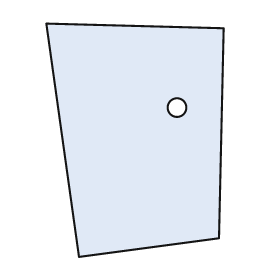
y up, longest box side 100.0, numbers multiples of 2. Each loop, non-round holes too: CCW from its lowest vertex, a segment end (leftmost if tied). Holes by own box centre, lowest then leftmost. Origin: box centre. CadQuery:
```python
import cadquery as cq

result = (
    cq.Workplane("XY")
    .moveTo(-24.0, -50.0)
    .lineTo(36.0, -42.0)
    .lineTo(38.0, 48.0)
    .lineTo(-38.0, 50.0)
    .close()
    .moveTo(18.0, 14.0)
    .circle(4.0)
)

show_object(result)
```